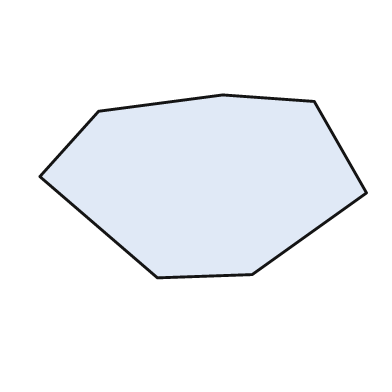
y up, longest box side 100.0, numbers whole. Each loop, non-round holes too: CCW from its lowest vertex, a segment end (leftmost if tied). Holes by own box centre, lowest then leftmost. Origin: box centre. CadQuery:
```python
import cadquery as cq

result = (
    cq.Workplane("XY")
    .moveTo(-14.0, -28.0)
    .lineTo(15.0, -27.0)
    .lineTo(50.0, -2.0)
    .lineTo(34.0, 26.0)
    .lineTo(6.0, 28.0)
    .lineTo(-32.0, 23.0)
    .lineTo(-50.0, 3.0)
    .close()
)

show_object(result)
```